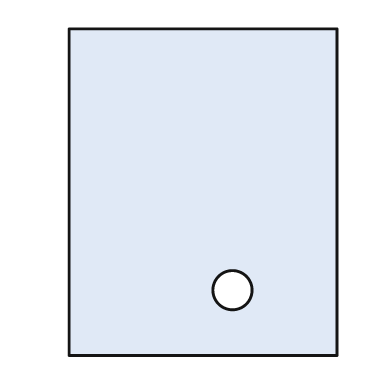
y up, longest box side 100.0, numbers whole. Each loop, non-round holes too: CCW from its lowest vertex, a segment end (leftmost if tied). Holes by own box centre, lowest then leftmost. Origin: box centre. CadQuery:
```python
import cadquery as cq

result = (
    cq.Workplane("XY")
    .moveTo(-41.0, -50.0)
    .lineTo(41.0, -50.0)
    .lineTo(41.0, 50.0)
    .lineTo(-41.0, 50.0)
    .close()
    .moveTo(9.0, -30.0)
    .circle(6.0)
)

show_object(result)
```